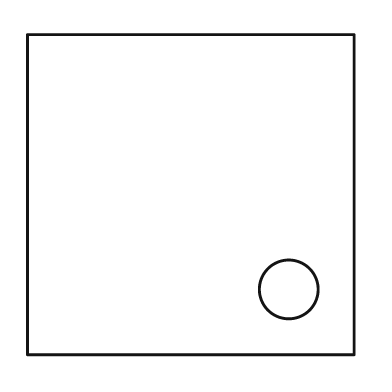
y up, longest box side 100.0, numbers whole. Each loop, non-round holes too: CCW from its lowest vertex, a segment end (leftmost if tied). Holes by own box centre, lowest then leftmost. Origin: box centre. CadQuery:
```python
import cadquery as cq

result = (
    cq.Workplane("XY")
    .moveTo(-50.0, -49.0)
    .lineTo(50.0, -49.0)
    .lineTo(50.0, 49.0)
    .lineTo(-50.0, 49.0)
    .close()
    .moveTo(30.0, -29.0)
    .circle(9.0)
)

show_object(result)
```